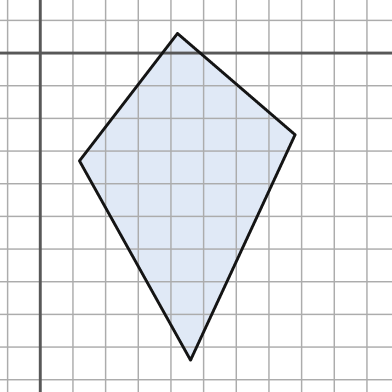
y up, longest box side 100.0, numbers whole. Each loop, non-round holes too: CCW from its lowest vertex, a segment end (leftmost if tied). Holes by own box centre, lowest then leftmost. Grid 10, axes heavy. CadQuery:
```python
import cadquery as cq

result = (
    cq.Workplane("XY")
    .moveTo(46.0, -94.0)
    .lineTo(78.0, -25.0)
    .lineTo(42.0, 6.0)
    .lineTo(12.0, -33.0)
    .close()
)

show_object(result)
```